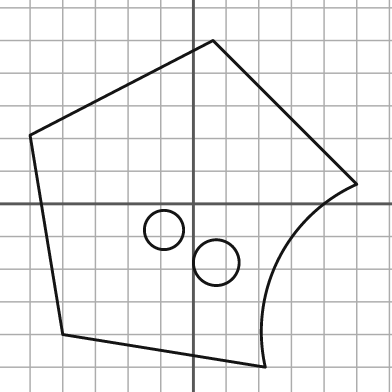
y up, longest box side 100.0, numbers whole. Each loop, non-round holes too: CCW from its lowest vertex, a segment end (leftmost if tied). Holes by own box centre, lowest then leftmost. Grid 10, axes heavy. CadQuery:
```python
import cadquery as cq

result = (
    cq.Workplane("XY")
    .moveTo(22.0, -50.0)
    .threePointArc((26.0, -17.0), (50.0, 6.0))
    .lineTo(6.0, 50.0)
    .lineTo(-50.0, 21.0)
    .lineTo(-40.0, -40.0)
    .close()
    .moveTo(7.0, -18.0)
    .circle(7.0)
    .moveTo(-9.0, -8.0)
    .circle(6.0)
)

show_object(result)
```